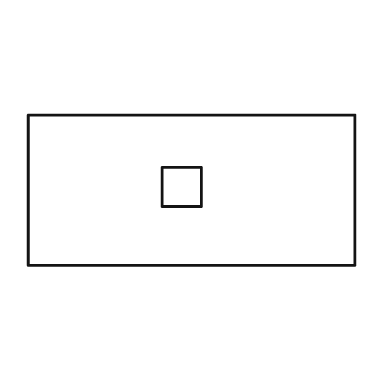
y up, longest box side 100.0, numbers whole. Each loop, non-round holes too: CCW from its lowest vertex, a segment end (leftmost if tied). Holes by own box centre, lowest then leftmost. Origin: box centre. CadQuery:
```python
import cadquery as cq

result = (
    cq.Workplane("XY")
    .moveTo(-50.0, -23.0)
    .lineTo(50.0, -23.0)
    .lineTo(50.0, 23.0)
    .lineTo(-50.0, 23.0)
    .close()
    .moveTo(-9.0, -5.0)
    .lineTo(3.0, -5.0)
    .lineTo(3.0, 7.0)
    .lineTo(-9.0, 7.0)
    .close()
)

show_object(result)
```